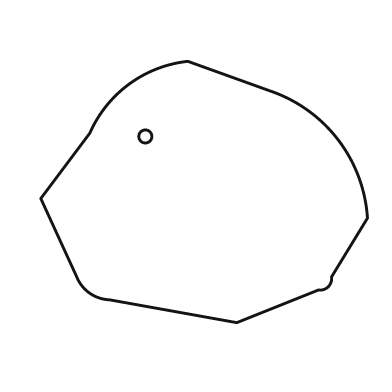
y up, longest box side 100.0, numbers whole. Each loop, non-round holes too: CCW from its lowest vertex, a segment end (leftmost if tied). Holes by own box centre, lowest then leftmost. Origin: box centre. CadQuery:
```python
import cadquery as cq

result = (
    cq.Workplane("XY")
    .moveTo(10.0, -40.0)
    .lineTo(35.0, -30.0)
    .threePointArc((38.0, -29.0), (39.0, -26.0))
    .lineTo(50.0, -8.0)
    .threePointArc((41.0, 16.0), (20.0, 31.0))
    .lineTo(-5.0, 40.0)
    .threePointArc((-23.0, 33.0), (-35.0, 18.0))
    .lineTo(-50.0, -2.0)
    .lineTo(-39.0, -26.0)
    .threePointArc((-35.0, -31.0), (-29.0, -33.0))
    .close()
    .moveTo(-18.0, 17.0)
    .circle(2.0)
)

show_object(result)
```